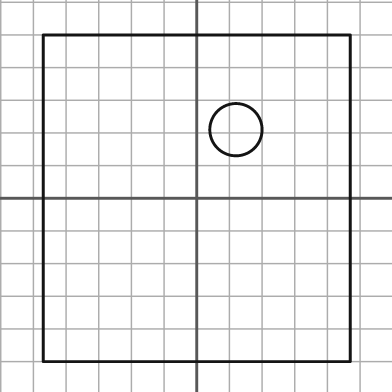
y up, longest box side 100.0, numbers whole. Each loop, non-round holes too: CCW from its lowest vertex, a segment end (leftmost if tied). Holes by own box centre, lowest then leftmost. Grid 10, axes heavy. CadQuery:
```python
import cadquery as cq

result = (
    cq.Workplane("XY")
    .moveTo(-47.0, -50.0)
    .lineTo(47.0, -50.0)
    .lineTo(47.0, 50.0)
    .lineTo(-47.0, 50.0)
    .close()
    .moveTo(12.0, 21.0)
    .circle(8.0)
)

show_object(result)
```